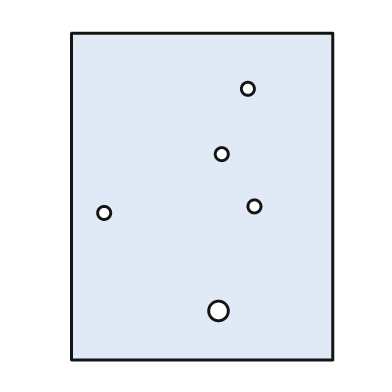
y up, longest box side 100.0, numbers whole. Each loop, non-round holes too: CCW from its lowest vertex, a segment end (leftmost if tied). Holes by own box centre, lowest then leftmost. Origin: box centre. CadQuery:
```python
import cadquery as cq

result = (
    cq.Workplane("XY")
    .moveTo(-40.0, -50.0)
    .lineTo(40.0, -50.0)
    .lineTo(40.0, 50.0)
    .lineTo(-40.0, 50.0)
    .close()
    .moveTo(5.0, -35.0)
    .circle(3.0)
    .moveTo(-30.0, -5.0)
    .circle(2.0)
    .moveTo(16.0, -3.0)
    .circle(2.0)
    .moveTo(6.0, 13.0)
    .circle(2.0)
    .moveTo(14.0, 33.0)
    .circle(2.0)
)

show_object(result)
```